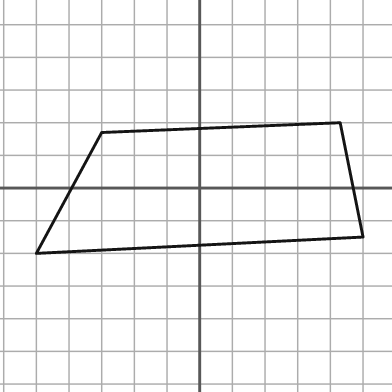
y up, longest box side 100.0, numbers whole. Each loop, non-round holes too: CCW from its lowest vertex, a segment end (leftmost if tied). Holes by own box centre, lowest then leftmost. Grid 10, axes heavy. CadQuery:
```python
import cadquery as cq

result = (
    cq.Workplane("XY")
    .moveTo(-50.0, -20.0)
    .lineTo(50.0, -15.0)
    .lineTo(43.0, 20.0)
    .lineTo(-30.0, 17.0)
    .close()
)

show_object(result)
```